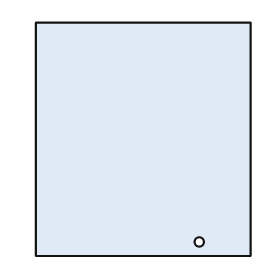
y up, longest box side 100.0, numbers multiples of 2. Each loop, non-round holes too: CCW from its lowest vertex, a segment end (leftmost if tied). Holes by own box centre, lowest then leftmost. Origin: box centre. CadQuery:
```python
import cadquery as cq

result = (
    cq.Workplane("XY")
    .moveTo(-46.0, -50.0)
    .lineTo(46.0, -50.0)
    .lineTo(46.0, 50.0)
    .lineTo(-46.0, 50.0)
    .close()
    .moveTo(24.0, -44.0)
    .circle(2.0)
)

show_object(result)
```